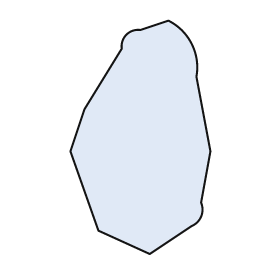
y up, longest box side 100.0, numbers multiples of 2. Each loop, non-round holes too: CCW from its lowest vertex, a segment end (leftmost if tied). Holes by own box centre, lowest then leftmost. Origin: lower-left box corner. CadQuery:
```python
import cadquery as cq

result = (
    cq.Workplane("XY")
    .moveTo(34.0, 0.0)
    .lineTo(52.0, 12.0)
    .threePointArc((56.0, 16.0), (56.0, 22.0))
    .lineTo(60.0, 44.0)
    .lineTo(54.0, 76.0)
    .threePointArc((52.0, 90.0), (42.0, 100.0))
    .lineTo(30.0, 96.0)
    .threePointArc((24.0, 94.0), (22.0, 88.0))
    .lineTo(6.0, 62.0)
    .lineTo(0.0, 44.0)
    .lineTo(12.0, 10.0)
    .close()
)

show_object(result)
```